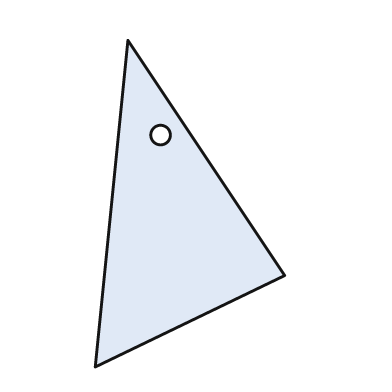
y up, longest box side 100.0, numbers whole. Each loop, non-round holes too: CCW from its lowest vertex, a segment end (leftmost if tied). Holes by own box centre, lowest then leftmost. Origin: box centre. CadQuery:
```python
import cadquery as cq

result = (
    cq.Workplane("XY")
    .moveTo(-29.0, -50.0)
    .lineTo(29.0, -22.0)
    .lineTo(-19.0, 50.0)
    .close()
    .moveTo(-9.0, 21.0)
    .circle(3.0)
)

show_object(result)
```